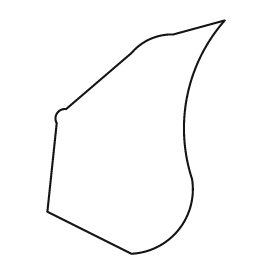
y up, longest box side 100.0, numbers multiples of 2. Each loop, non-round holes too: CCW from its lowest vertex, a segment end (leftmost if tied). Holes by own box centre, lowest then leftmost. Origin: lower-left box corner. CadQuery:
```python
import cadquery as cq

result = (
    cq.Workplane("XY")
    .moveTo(36.0, 0.0)
    .threePointArc((56.0, 10.0), (62.0, 32.0))
    .threePointArc((60.0, 68.0), (76.0, 100.0))
    .lineTo(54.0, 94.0)
    .threePointArc((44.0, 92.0), (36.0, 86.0))
    .lineTo(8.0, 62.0)
    .threePointArc((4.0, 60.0), (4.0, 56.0))
    .lineTo(0.0, 18.0)
    .close()
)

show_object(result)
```